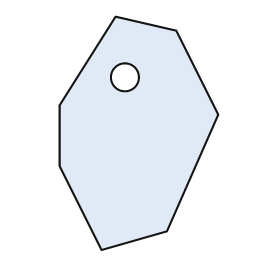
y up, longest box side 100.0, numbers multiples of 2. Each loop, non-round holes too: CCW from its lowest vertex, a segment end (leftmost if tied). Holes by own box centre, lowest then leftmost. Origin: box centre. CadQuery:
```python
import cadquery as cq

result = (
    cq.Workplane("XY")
    .moveTo(-16.0, -50.0)
    .lineTo(12.0, -42.0)
    .lineTo(34.0, 8.0)
    .lineTo(16.0, 44.0)
    .lineTo(-10.0, 50.0)
    .lineTo(-34.0, 12.0)
    .lineTo(-34.0, -14.0)
    .close()
    .moveTo(-6.0, 24.0)
    .circle(6.0)
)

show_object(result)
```